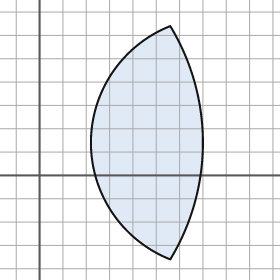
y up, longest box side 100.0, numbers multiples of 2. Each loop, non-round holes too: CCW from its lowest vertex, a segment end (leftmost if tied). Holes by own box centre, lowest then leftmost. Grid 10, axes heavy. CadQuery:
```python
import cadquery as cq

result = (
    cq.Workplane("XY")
    .moveTo(56.0, -36.0)
    .threePointArc((70.0, 14.0), (56.0, 64.0))
    .threePointArc((22.0, 14.0), (56.0, -36.0))
    .close()
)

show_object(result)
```